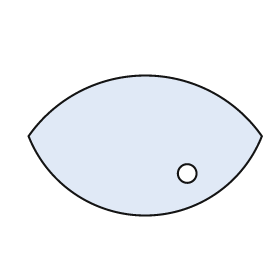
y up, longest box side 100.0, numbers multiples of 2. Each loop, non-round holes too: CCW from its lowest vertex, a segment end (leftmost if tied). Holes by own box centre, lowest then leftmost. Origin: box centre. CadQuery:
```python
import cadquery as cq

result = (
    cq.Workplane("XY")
    .moveTo(-50.0, 4.0)
    .threePointArc((0.0, -30.0), (50.0, 4.0))
    .threePointArc((0.0, 30.0), (-50.0, 4.0))
    .close()
    .moveTo(18.0, -12.0)
    .circle(4.0)
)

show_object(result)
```